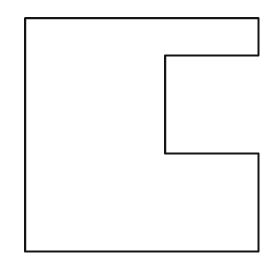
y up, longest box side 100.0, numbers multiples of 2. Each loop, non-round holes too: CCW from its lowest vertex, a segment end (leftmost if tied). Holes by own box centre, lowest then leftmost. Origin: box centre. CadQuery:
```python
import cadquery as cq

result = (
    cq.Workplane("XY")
    .moveTo(-50.0, -50.0)
    .lineTo(50.0, -50.0)
    .lineTo(50.0, -8.0)
    .lineTo(10.0, -8.0)
    .lineTo(10.0, 34.0)
    .lineTo(50.0, 34.0)
    .lineTo(50.0, 50.0)
    .lineTo(-50.0, 50.0)
    .close()
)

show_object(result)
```